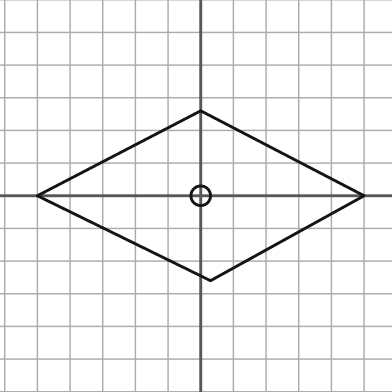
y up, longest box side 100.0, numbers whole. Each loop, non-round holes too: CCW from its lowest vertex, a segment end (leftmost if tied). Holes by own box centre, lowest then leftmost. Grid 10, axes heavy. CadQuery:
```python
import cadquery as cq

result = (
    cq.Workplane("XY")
    .moveTo(3.0, -26.0)
    .lineTo(50.0, 0.0)
    .lineTo(0.0, 26.0)
    .lineTo(-50.0, 0.0)
    .close()
    .moveTo(0.0, 0.0)
    .circle(3.0)
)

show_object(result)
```